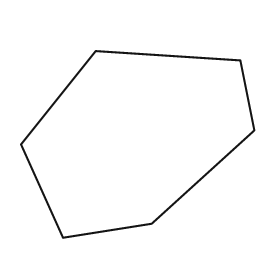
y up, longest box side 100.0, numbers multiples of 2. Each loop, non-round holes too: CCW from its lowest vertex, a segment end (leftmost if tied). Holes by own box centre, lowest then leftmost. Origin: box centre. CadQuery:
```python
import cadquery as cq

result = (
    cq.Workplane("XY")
    .moveTo(-32.0, -40.0)
    .lineTo(6.0, -34.0)
    .lineTo(50.0, 6.0)
    .lineTo(44.0, 36.0)
    .lineTo(-18.0, 40.0)
    .lineTo(-50.0, 0.0)
    .close()
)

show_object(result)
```